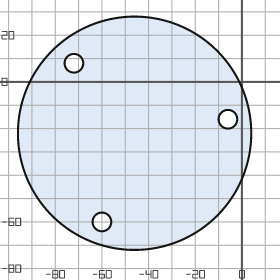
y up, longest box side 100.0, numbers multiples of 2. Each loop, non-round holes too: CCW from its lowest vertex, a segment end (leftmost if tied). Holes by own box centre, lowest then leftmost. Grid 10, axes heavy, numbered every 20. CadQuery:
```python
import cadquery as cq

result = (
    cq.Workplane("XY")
    .moveTo(-46.0, -22.0)
    .circle(50.0)
    .moveTo(-60.0, -60.0)
    .circle(4.0)
    .moveTo(-6.0, -16.0)
    .circle(4.0)
    .moveTo(-72.0, 8.0)
    .circle(4.0)
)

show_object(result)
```